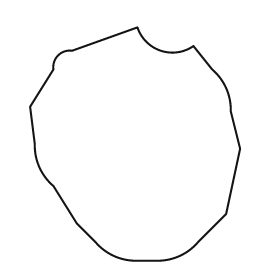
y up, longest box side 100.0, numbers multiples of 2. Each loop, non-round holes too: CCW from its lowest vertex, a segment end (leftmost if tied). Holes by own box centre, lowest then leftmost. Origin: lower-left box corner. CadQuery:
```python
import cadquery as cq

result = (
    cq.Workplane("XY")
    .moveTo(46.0, 0.0)
    .lineTo(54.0, 0.0)
    .threePointArc((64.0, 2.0), (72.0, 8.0))
    .lineTo(84.0, 20.0)
    .lineTo(90.0, 48.0)
    .lineTo(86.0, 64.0)
    .threePointArc((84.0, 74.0), (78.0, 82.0))
    .lineTo(70.0, 92.0)
    .threePointArc((56.0, 90.0), (46.0, 100.0))
    .lineTo(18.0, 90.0)
    .threePointArc((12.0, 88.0), (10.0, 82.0))
    .lineTo(0.0, 66.0)
    .lineTo(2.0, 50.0)
    .threePointArc((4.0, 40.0), (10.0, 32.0))
    .lineTo(20.0, 16.0)
    .lineTo(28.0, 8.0)
    .threePointArc((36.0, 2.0), (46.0, 0.0))
    .close()
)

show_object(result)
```